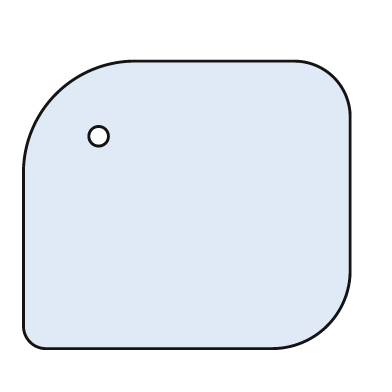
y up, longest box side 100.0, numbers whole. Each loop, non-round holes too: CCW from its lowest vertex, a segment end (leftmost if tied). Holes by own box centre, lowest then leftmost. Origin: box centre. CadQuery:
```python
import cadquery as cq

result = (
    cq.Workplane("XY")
    .moveTo(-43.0, -44.0)
    .lineTo(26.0, -44.0)
    .threePointArc((43.0, -37.0), (50.0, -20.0))
    .lineTo(50.0, 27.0)
    .threePointArc((45.0, 39.0), (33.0, 44.0))
    .lineTo(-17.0, 44.0)
    .threePointArc((-40.0, 34.0), (-50.0, 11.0))
    .lineTo(-50.0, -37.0)
    .threePointArc((-48.0, -42.0), (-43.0, -44.0))
    .close()
    .moveTo(-27.0, 21.0)
    .circle(3.0)
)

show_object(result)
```